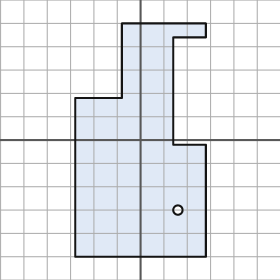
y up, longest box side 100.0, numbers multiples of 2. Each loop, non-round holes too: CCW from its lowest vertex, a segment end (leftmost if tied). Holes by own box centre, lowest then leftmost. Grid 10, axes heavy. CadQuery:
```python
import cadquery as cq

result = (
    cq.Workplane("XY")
    .moveTo(-28.0, -50.0)
    .lineTo(28.0, -50.0)
    .lineTo(28.0, -2.0)
    .lineTo(14.0, -2.0)
    .lineTo(14.0, 44.0)
    .lineTo(28.0, 44.0)
    .lineTo(28.0, 50.0)
    .lineTo(-8.0, 50.0)
    .lineTo(-8.0, 18.0)
    .lineTo(-28.0, 18.0)
    .close()
    .moveTo(16.0, -30.0)
    .circle(2.0)
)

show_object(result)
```